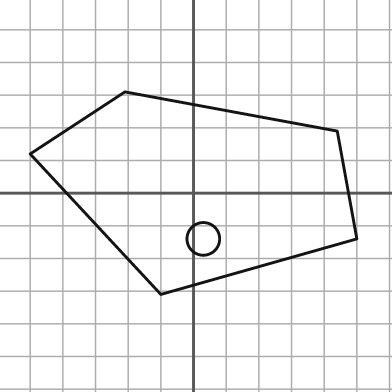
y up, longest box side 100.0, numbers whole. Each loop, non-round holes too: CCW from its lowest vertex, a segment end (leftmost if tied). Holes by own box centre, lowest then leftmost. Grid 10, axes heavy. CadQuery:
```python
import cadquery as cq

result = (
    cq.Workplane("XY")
    .moveTo(-10.0, -31.0)
    .lineTo(50.0, -14.0)
    .lineTo(44.0, 19.0)
    .lineTo(-21.0, 31.0)
    .lineTo(-50.0, 12.0)
    .close()
    .moveTo(3.0, -14.0)
    .circle(5.0)
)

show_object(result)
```